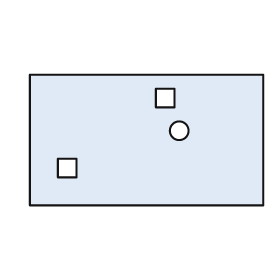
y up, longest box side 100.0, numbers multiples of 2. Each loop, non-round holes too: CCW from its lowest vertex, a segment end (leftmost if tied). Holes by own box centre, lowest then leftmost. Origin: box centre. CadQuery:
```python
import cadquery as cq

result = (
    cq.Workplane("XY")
    .moveTo(-50.0, -28.0)
    .lineTo(50.0, -28.0)
    .lineTo(50.0, 28.0)
    .lineTo(-50.0, 28.0)
    .close()
    .moveTo(-38.0, -16.0)
    .lineTo(-30.0, -16.0)
    .lineTo(-30.0, -8.0)
    .lineTo(-38.0, -8.0)
    .close()
    .moveTo(14.0, 4.0)
    .circle(4.0)
    .moveTo(4.0, 14.0)
    .lineTo(12.0, 14.0)
    .lineTo(12.0, 22.0)
    .lineTo(4.0, 22.0)
    .close()
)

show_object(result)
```